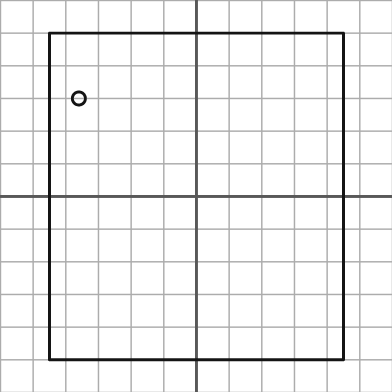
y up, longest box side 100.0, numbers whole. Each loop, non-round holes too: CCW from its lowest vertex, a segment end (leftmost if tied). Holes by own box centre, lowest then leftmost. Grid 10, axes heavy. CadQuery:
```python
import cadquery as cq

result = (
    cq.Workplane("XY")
    .moveTo(-45.0, -50.0)
    .lineTo(45.0, -50.0)
    .lineTo(45.0, 50.0)
    .lineTo(-45.0, 50.0)
    .close()
    .moveTo(-36.0, 30.0)
    .circle(2.0)
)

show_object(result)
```